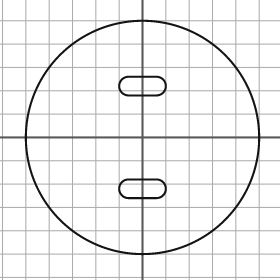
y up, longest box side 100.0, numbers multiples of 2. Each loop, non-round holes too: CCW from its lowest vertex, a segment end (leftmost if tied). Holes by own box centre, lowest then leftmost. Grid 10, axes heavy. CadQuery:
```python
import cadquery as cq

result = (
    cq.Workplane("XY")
    .moveTo(0.0, 0.0)
    .circle(50.0)
    .moveTo(-6.0, -26.0)
    .lineTo(6.0, -26.0)
    .threePointArc((10.0, -22.0), (6.0, -18.0))
    .lineTo(-6.0, -18.0)
    .threePointArc((-10.0, -22.0), (-6.0, -26.0))
    .close()
    .moveTo(-6.0, 18.0)
    .lineTo(6.0, 18.0)
    .threePointArc((10.0, 22.0), (6.0, 26.0))
    .lineTo(-6.0, 26.0)
    .threePointArc((-10.0, 22.0), (-6.0, 18.0))
    .close()
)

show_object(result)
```